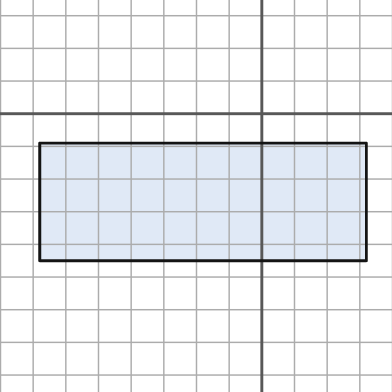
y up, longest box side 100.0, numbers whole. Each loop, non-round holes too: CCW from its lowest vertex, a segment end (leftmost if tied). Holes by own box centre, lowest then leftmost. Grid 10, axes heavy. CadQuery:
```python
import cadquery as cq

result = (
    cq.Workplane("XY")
    .moveTo(-68.0, -45.0)
    .lineTo(32.0, -45.0)
    .lineTo(32.0, -9.0)
    .lineTo(-68.0, -9.0)
    .close()
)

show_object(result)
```